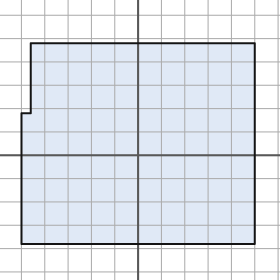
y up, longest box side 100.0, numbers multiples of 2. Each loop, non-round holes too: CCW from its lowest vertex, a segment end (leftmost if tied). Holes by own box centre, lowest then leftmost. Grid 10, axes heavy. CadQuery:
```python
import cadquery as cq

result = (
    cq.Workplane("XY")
    .moveTo(-50.0, -38.0)
    .lineTo(50.0, -38.0)
    .lineTo(50.0, 48.0)
    .lineTo(-46.0, 48.0)
    .lineTo(-46.0, 18.0)
    .lineTo(-50.0, 18.0)
    .close()
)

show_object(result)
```